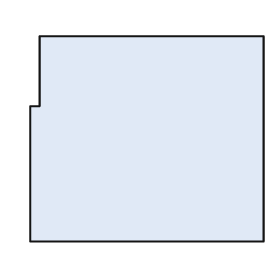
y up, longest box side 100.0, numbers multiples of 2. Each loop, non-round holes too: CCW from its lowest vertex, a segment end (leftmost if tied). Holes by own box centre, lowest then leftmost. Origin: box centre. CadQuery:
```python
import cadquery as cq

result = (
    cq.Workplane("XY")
    .moveTo(-50.0, -44.0)
    .lineTo(50.0, -44.0)
    .lineTo(50.0, 44.0)
    .lineTo(-46.0, 44.0)
    .lineTo(-46.0, 14.0)
    .lineTo(-50.0, 14.0)
    .close()
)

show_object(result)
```